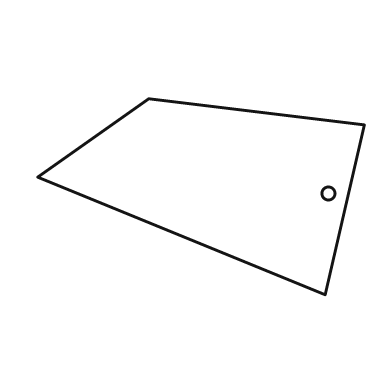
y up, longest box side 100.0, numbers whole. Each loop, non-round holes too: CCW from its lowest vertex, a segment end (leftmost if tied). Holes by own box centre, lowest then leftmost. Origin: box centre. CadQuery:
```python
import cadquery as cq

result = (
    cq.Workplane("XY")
    .moveTo(38.0, -30.0)
    .lineTo(50.0, 22.0)
    .lineTo(-16.0, 30.0)
    .lineTo(-50.0, 6.0)
    .close()
    .moveTo(39.0, 1.0)
    .circle(2.0)
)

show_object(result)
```